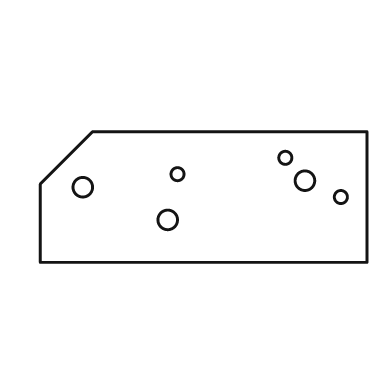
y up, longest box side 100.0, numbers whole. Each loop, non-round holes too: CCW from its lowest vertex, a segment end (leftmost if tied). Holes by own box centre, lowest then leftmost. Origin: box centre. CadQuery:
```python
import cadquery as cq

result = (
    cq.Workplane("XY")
    .moveTo(-50.0, -20.0)
    .lineTo(50.0, -20.0)
    .lineTo(50.0, 20.0)
    .lineTo(-34.0, 20.0)
    .lineTo(-50.0, 4.0)
    .close()
    .moveTo(-11.0, -7.0)
    .circle(3.0)
    .moveTo(42.0, 0.0)
    .circle(2.0)
    .moveTo(-37.0, 3.0)
    .circle(3.0)
    .moveTo(31.0, 5.0)
    .circle(3.0)
    .moveTo(-8.0, 7.0)
    .circle(2.0)
    .moveTo(25.0, 12.0)
    .circle(2.0)
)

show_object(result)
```